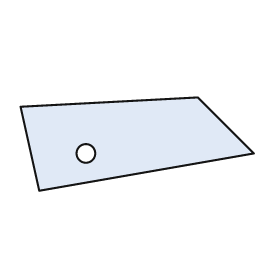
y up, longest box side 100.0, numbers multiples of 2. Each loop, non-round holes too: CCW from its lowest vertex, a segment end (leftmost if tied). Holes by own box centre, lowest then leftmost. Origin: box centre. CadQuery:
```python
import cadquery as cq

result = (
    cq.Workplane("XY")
    .moveTo(-42.0, -20.0)
    .lineTo(50.0, -4.0)
    .lineTo(26.0, 20.0)
    .lineTo(-50.0, 16.0)
    .close()
    .moveTo(-22.0, -4.0)
    .circle(4.0)
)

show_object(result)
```